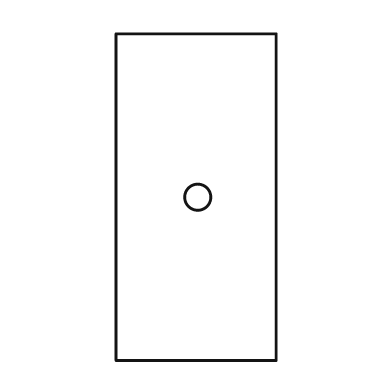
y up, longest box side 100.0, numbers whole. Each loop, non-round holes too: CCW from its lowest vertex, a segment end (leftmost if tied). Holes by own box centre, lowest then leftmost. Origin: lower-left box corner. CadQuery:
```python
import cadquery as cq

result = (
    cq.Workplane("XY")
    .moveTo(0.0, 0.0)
    .lineTo(49.0, 0.0)
    .lineTo(49.0, 100.0)
    .lineTo(0.0, 100.0)
    .close()
    .moveTo(25.0, 50.0)
    .circle(4.0)
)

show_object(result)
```